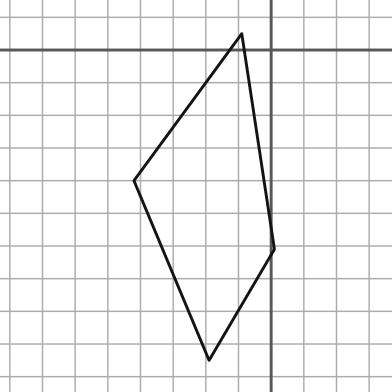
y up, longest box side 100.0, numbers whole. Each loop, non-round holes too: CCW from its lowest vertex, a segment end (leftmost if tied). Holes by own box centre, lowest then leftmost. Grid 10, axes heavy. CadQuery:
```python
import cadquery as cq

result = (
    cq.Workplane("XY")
    .moveTo(-19.0, -95.0)
    .lineTo(1.0, -61.0)
    .lineTo(-9.0, 5.0)
    .lineTo(-42.0, -40.0)
    .close()
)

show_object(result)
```